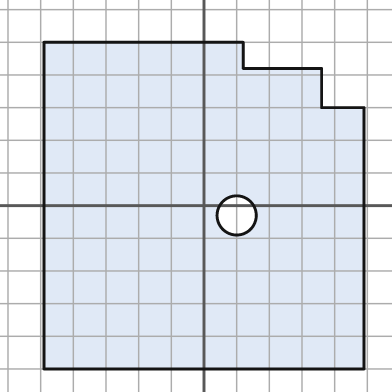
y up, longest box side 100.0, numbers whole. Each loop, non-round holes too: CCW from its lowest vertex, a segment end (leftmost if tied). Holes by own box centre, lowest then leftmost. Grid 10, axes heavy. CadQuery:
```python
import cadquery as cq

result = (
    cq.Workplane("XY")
    .moveTo(-49.0, -50.0)
    .lineTo(49.0, -50.0)
    .lineTo(49.0, 30.0)
    .lineTo(36.0, 30.0)
    .lineTo(36.0, 42.0)
    .lineTo(12.0, 42.0)
    .lineTo(12.0, 50.0)
    .lineTo(-49.0, 50.0)
    .close()
    .moveTo(10.0, -3.0)
    .circle(6.0)
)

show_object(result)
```